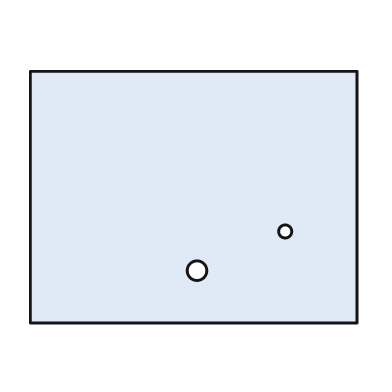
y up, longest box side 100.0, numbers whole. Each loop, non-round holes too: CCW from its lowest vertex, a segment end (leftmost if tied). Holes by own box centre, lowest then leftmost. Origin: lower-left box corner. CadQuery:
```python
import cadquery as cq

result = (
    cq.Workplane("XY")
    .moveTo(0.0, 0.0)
    .lineTo(100.0, 0.0)
    .lineTo(100.0, 77.0)
    .lineTo(0.0, 77.0)
    .close()
    .moveTo(51.0, 16.0)
    .circle(3.0)
    .moveTo(78.0, 28.0)
    .circle(2.0)
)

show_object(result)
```